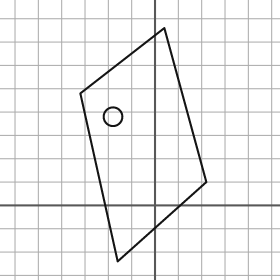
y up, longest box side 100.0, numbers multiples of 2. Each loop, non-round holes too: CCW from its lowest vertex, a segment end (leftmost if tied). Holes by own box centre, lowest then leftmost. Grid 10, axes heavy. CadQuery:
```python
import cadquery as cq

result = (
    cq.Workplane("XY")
    .moveTo(-16.0, -24.0)
    .lineTo(22.0, 10.0)
    .lineTo(4.0, 76.0)
    .lineTo(-32.0, 48.0)
    .close()
    .moveTo(-18.0, 38.0)
    .circle(4.0)
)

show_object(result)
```